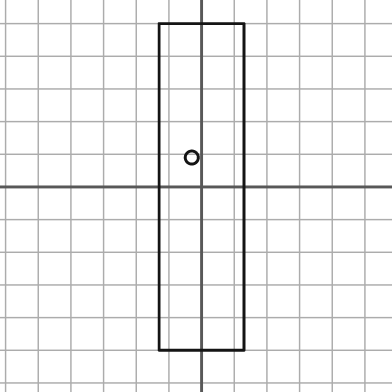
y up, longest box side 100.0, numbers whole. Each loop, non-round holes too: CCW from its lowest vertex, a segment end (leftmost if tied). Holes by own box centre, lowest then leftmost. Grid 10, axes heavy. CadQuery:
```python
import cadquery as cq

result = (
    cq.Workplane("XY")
    .moveTo(-13.0, -50.0)
    .lineTo(13.0, -50.0)
    .lineTo(13.0, 50.0)
    .lineTo(-13.0, 50.0)
    .close()
    .moveTo(-3.0, 9.0)
    .circle(2.0)
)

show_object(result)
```